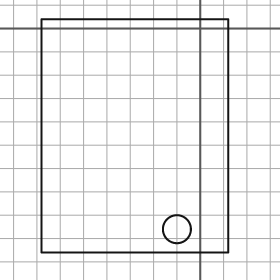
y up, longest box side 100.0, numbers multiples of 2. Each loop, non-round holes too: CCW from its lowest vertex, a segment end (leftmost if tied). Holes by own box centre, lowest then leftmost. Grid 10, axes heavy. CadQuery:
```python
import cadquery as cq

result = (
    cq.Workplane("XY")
    .moveTo(-68.0, -96.0)
    .lineTo(12.0, -96.0)
    .lineTo(12.0, 4.0)
    .lineTo(-68.0, 4.0)
    .close()
    .moveTo(-10.0, -86.0)
    .circle(6.0)
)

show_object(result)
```